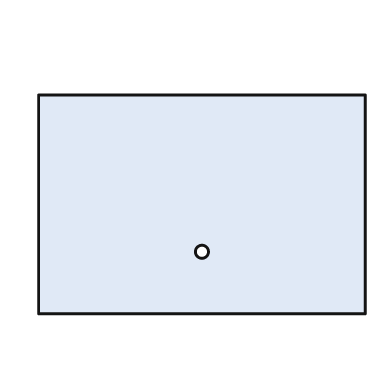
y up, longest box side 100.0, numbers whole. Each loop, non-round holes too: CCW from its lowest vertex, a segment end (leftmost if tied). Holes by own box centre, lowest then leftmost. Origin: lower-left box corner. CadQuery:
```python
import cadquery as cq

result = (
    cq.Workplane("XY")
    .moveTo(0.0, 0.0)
    .lineTo(100.0, 0.0)
    .lineTo(100.0, 67.0)
    .lineTo(0.0, 67.0)
    .close()
    .moveTo(50.0, 19.0)
    .circle(2.0)
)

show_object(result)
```